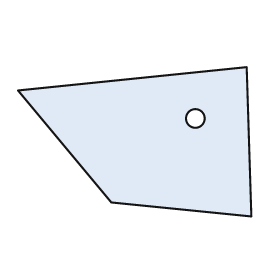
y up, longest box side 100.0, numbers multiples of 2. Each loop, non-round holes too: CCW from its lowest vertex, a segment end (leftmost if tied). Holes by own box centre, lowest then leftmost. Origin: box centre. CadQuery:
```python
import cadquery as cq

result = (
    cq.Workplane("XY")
    .moveTo(50.0, -32.0)
    .lineTo(48.0, 32.0)
    .lineTo(-50.0, 22.0)
    .lineTo(-10.0, -26.0)
    .close()
    .moveTo(26.0, 10.0)
    .circle(4.0)
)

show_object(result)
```